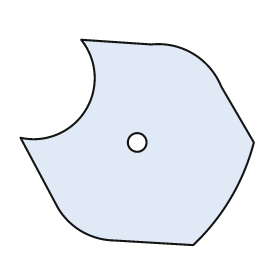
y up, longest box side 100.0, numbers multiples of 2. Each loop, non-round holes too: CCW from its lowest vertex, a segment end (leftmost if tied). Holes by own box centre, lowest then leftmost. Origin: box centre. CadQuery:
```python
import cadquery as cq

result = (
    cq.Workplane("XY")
    .moveTo(24.0, -44.0)
    .threePointArc((40.0, -24.0), (50.0, 0.0))
    .lineTo(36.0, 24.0)
    .threePointArc((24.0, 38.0), (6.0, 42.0))
    .lineTo(-24.0, 44.0)
    .threePointArc((-22.0, 14.0), (-50.0, 2.0))
    .lineTo(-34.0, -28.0)
    .threePointArc((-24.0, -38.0), (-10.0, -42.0))
    .close()
    .moveTo(0.0, 0.0)
    .circle(4.0)
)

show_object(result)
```